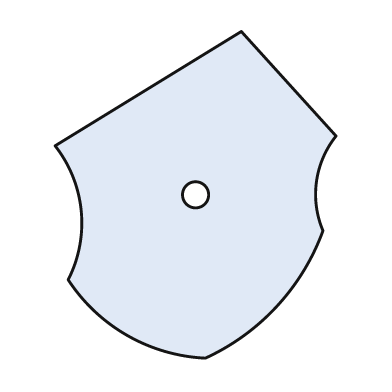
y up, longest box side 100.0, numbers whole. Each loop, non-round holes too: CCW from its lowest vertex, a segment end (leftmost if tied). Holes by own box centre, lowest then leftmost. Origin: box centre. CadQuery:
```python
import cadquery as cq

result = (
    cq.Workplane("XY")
    .moveTo(3.0, -50.0)
    .threePointArc((25.0, -34.0), (39.0, -11.0))
    .threePointArc((37.0, 4.0), (43.0, 18.0))
    .lineTo(14.0, 50.0)
    .lineTo(-43.0, 15.0)
    .threePointArc((-35.0, -5.0), (-39.0, -26.0))
    .threePointArc((-21.0, -43.0), (3.0, -50.0))
    .close()
    .moveTo(0.0, 0.0)
    .circle(4.0)
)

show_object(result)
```